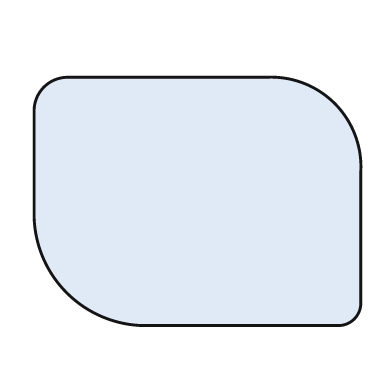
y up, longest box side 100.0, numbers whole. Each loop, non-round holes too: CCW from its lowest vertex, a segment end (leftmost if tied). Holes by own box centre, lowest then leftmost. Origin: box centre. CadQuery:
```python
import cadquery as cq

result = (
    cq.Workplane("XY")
    .moveTo(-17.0, -38.0)
    .lineTo(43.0, -38.0)
    .threePointArc((48.0, -36.0), (50.0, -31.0))
    .lineTo(50.0, 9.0)
    .threePointArc((42.0, 30.0), (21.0, 38.0))
    .lineTo(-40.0, 38.0)
    .threePointArc((-47.0, 35.0), (-50.0, 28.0))
    .lineTo(-50.0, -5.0)
    .threePointArc((-40.0, -28.0), (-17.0, -38.0))
    .close()
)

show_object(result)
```